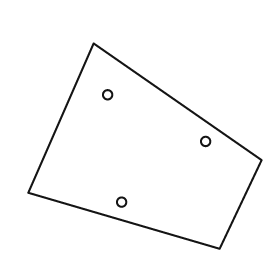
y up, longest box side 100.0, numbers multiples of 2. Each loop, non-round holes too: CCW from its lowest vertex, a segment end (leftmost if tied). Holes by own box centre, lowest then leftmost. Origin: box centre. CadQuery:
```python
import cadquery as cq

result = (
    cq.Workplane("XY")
    .moveTo(32.0, -44.0)
    .lineTo(50.0, -6.0)
    .lineTo(-22.0, 44.0)
    .lineTo(-50.0, -20.0)
    .close()
    .moveTo(-10.0, -24.0)
    .circle(2.0)
    .moveTo(26.0, 2.0)
    .circle(2.0)
    .moveTo(-16.0, 22.0)
    .circle(2.0)
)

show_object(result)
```